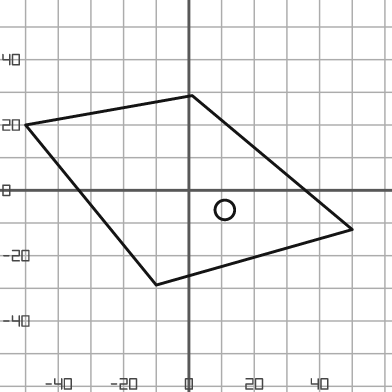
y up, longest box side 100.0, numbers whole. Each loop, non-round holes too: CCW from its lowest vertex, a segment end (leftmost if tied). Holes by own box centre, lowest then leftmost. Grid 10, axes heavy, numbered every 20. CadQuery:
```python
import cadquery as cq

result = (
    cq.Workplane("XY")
    .moveTo(-10.0, -29.0)
    .lineTo(50.0, -12.0)
    .lineTo(1.0, 29.0)
    .lineTo(-50.0, 20.0)
    .close()
    .moveTo(11.0, -6.0)
    .circle(3.0)
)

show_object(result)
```